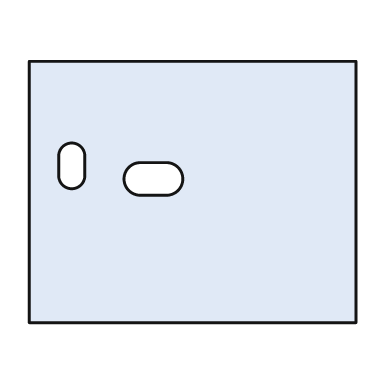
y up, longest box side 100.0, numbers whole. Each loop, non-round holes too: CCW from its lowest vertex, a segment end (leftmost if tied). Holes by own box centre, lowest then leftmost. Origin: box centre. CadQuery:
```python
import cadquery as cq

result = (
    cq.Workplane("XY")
    .moveTo(-50.0, -40.0)
    .lineTo(50.0, -40.0)
    .lineTo(50.0, 40.0)
    .lineTo(-50.0, 40.0)
    .close()
    .moveTo(-16.0, -1.0)
    .lineTo(-8.0, -1.0)
    .threePointArc((-3.0, 4.0), (-8.0, 9.0))
    .lineTo(-16.0, 9.0)
    .threePointArc((-21.0, 4.0), (-16.0, -1.0))
    .close()
    .moveTo(-41.0, 5.0)
    .threePointArc((-37.0, 1.0), (-33.0, 5.0))
    .lineTo(-33.0, 11.0)
    .threePointArc((-37.0, 15.0), (-41.0, 11.0))
    .close()
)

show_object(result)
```